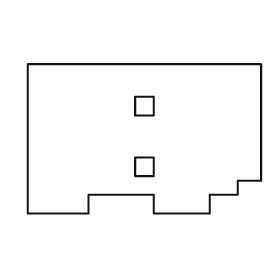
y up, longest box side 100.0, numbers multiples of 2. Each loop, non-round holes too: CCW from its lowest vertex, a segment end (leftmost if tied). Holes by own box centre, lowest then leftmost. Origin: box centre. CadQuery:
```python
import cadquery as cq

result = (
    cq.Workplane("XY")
    .moveTo(-50.0, -32.0)
    .lineTo(-24.0, -32.0)
    .lineTo(-24.0, -24.0)
    .lineTo(4.0, -24.0)
    .lineTo(4.0, -32.0)
    .lineTo(28.0, -32.0)
    .lineTo(28.0, -24.0)
    .lineTo(40.0, -24.0)
    .lineTo(40.0, -18.0)
    .lineTo(50.0, -18.0)
    .lineTo(50.0, 32.0)
    .lineTo(-50.0, 32.0)
    .close()
    .moveTo(-4.0, -16.0)
    .lineTo(4.0, -16.0)
    .lineTo(4.0, -8.0)
    .lineTo(-4.0, -8.0)
    .close()
    .moveTo(-4.0, 10.0)
    .lineTo(4.0, 10.0)
    .lineTo(4.0, 18.0)
    .lineTo(-4.0, 18.0)
    .close()
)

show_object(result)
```